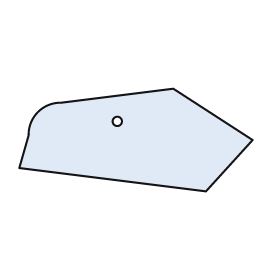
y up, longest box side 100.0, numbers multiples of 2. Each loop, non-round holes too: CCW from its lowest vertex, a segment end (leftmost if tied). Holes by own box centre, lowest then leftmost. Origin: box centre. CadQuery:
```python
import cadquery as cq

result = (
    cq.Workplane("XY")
    .moveTo(30.0, -22.0)
    .lineTo(50.0, 0.0)
    .lineTo(16.0, 22.0)
    .lineTo(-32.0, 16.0)
    .threePointArc((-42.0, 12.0), (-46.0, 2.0))
    .lineTo(-50.0, -12.0)
    .close()
    .moveTo(-8.0, 8.0)
    .circle(2.0)
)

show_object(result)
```